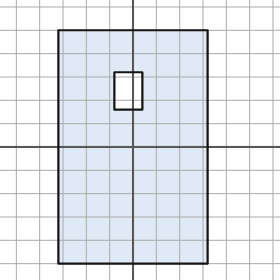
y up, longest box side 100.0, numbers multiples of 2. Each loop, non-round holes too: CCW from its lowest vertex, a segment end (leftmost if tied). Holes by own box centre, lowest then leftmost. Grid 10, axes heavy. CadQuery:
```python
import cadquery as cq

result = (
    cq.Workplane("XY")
    .moveTo(-32.0, -50.0)
    .lineTo(32.0, -50.0)
    .lineTo(32.0, 50.0)
    .lineTo(-32.0, 50.0)
    .close()
    .moveTo(-8.0, 16.0)
    .lineTo(4.0, 16.0)
    .lineTo(4.0, 32.0)
    .lineTo(-8.0, 32.0)
    .close()
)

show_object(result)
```